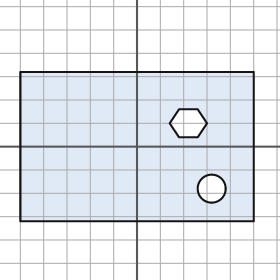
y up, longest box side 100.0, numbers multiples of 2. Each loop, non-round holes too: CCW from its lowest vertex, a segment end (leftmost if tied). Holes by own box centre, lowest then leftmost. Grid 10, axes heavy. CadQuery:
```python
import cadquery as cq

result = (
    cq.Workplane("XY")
    .moveTo(-50.0, -32.0)
    .lineTo(50.0, -32.0)
    .lineTo(50.0, 32.0)
    .lineTo(-50.0, 32.0)
    .close()
    .moveTo(32.0, -18.0)
    .circle(6.0)
    .moveTo(18.0, 4.0)
    .lineTo(26.0, 4.0)
    .lineTo(30.0, 10.0)
    .lineTo(26.0, 16.0)
    .lineTo(18.0, 16.0)
    .lineTo(14.0, 10.0)
    .close()
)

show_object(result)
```